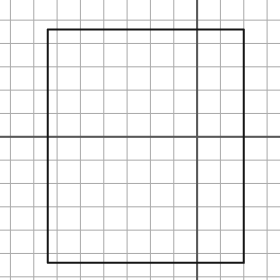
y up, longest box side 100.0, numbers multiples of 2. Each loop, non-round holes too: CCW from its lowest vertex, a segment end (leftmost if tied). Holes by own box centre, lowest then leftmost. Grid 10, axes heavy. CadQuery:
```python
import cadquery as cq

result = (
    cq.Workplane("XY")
    .moveTo(-64.0, -54.0)
    .lineTo(20.0, -54.0)
    .lineTo(20.0, 46.0)
    .lineTo(-64.0, 46.0)
    .close()
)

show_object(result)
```